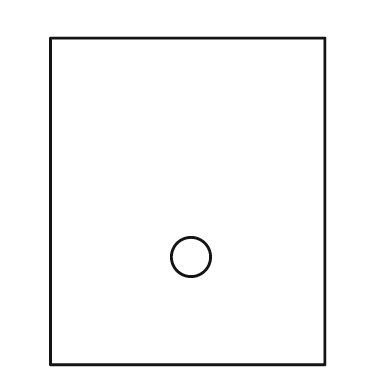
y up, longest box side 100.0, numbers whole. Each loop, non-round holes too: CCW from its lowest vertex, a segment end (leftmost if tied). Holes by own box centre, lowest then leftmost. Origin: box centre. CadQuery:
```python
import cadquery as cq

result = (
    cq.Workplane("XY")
    .moveTo(-42.0, -50.0)
    .lineTo(42.0, -50.0)
    .lineTo(42.0, 50.0)
    .lineTo(-42.0, 50.0)
    .close()
    .moveTo(1.0, -17.0)
    .circle(6.0)
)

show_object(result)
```